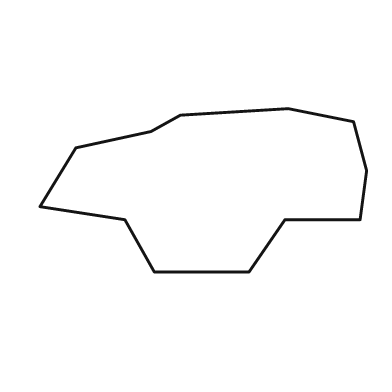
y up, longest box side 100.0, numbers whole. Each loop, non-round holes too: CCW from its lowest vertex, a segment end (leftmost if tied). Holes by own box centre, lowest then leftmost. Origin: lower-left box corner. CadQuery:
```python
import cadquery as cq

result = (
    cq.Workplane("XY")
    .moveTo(35.0, 0.0)
    .lineTo(64.0, 0.0)
    .lineTo(75.0, 16.0)
    .lineTo(98.0, 16.0)
    .lineTo(100.0, 31.0)
    .lineTo(96.0, 46.0)
    .lineTo(76.0, 50.0)
    .lineTo(43.0, 48.0)
    .lineTo(34.0, 43.0)
    .lineTo(11.0, 38.0)
    .lineTo(0.0, 20.0)
    .lineTo(26.0, 16.0)
    .close()
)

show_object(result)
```